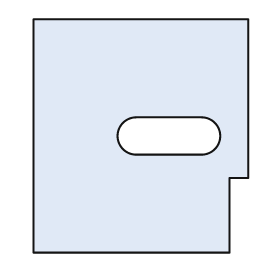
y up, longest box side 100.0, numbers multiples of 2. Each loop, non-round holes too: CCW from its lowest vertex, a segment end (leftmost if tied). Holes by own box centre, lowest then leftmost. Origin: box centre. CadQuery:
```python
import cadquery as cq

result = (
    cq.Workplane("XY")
    .moveTo(-46.0, -50.0)
    .lineTo(38.0, -50.0)
    .lineTo(38.0, -18.0)
    .lineTo(46.0, -18.0)
    .lineTo(46.0, 50.0)
    .lineTo(-46.0, 50.0)
    .close()
    .moveTo(-2.0, -8.0)
    .lineTo(26.0, -8.0)
    .threePointArc((34.0, 0.0), (26.0, 8.0))
    .lineTo(-2.0, 8.0)
    .threePointArc((-10.0, 0.0), (-2.0, -8.0))
    .close()
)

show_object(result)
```